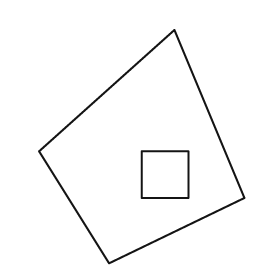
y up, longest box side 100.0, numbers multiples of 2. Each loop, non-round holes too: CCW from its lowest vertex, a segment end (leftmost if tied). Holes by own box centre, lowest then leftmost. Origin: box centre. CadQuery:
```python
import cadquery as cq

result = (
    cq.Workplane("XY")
    .moveTo(-14.0, -50.0)
    .lineTo(44.0, -22.0)
    .lineTo(14.0, 50.0)
    .lineTo(-44.0, -2.0)
    .close()
    .moveTo(0.0, -22.0)
    .lineTo(20.0, -22.0)
    .lineTo(20.0, -2.0)
    .lineTo(0.0, -2.0)
    .close()
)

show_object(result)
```